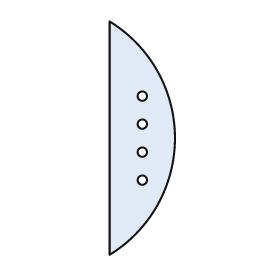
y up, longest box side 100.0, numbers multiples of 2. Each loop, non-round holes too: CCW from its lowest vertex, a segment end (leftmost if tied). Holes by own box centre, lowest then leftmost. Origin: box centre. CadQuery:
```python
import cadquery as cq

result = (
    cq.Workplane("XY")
    .moveTo(-14.0, -50.0)
    .threePointArc((14.0, 0.0), (-14.0, 50.0))
    .close()
    .moveTo(0.0, -18.0)
    .circle(2.0)
    .moveTo(0.0, -6.0)
    .circle(2.0)
    .moveTo(0.0, 6.0)
    .circle(2.0)
    .moveTo(0.0, 18.0)
    .circle(2.0)
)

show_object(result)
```